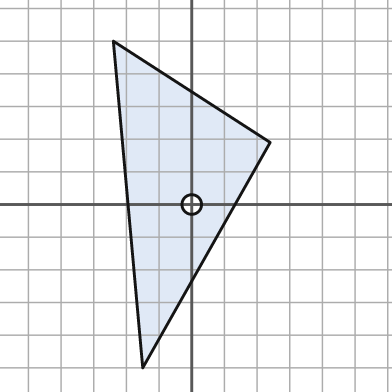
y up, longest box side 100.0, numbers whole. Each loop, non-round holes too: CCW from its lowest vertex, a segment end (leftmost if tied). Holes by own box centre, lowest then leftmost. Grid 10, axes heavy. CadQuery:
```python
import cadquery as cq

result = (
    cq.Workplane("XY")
    .moveTo(-15.0, -50.0)
    .lineTo(24.0, 19.0)
    .lineTo(-24.0, 50.0)
    .close()
    .moveTo(0.0, 0.0)
    .circle(3.0)
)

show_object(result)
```